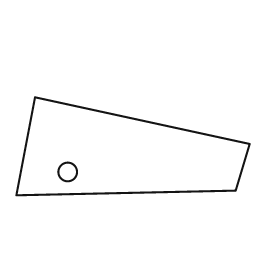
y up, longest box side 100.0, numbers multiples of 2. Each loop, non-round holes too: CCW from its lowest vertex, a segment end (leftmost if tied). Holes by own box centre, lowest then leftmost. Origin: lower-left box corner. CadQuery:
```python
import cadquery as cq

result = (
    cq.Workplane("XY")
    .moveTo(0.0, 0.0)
    .lineTo(94.0, 2.0)
    .lineTo(100.0, 22.0)
    .lineTo(8.0, 42.0)
    .close()
    .moveTo(22.0, 10.0)
    .circle(4.0)
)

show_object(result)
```